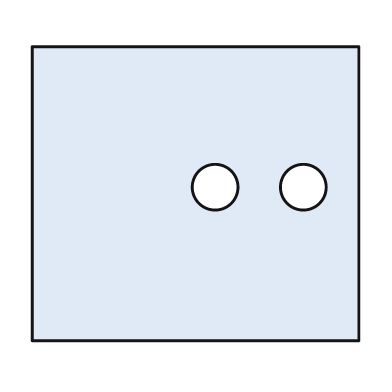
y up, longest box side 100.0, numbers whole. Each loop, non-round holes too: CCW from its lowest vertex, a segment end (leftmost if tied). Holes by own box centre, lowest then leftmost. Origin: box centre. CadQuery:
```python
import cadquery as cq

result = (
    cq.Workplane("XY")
    .moveTo(-50.0, -45.0)
    .lineTo(50.0, -45.0)
    .lineTo(50.0, 45.0)
    .lineTo(-50.0, 45.0)
    .close()
    .moveTo(6.0, 2.0)
    .circle(7.0)
    .moveTo(33.0, 2.0)
    .circle(7.0)
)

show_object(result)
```